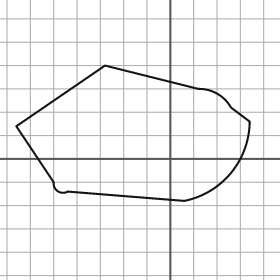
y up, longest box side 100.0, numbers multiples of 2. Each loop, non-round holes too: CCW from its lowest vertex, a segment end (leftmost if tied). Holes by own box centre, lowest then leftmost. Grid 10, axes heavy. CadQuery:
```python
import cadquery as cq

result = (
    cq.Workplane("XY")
    .moveTo(6.0, -18.0)
    .threePointArc((26.0, -6.0), (34.0, 16.0))
    .lineTo(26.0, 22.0)
    .threePointArc((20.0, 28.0), (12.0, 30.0))
    .lineTo(-28.0, 40.0)
    .lineTo(-66.0, 14.0)
    .lineTo(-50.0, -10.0)
    .threePointArc((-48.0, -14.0), (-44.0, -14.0))
    .close()
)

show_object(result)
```